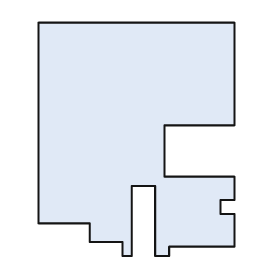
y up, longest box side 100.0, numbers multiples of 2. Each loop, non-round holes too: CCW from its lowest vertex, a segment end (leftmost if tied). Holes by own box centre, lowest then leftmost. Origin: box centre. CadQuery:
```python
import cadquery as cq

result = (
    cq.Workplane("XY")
    .moveTo(-6.0, -50.0)
    .lineTo(-2.0, -50.0)
    .lineTo(-2.0, -20.0)
    .lineTo(8.0, -20.0)
    .lineTo(8.0, -50.0)
    .lineTo(14.0, -50.0)
    .lineTo(14.0, -46.0)
    .lineTo(42.0, -46.0)
    .lineTo(42.0, -32.0)
    .lineTo(36.0, -32.0)
    .lineTo(36.0, -26.0)
    .lineTo(42.0, -26.0)
    .lineTo(42.0, -16.0)
    .lineTo(12.0, -16.0)
    .lineTo(12.0, 6.0)
    .lineTo(42.0, 6.0)
    .lineTo(42.0, 50.0)
    .lineTo(-42.0, 50.0)
    .lineTo(-42.0, -36.0)
    .lineTo(-20.0, -36.0)
    .lineTo(-20.0, -44.0)
    .lineTo(-6.0, -44.0)
    .close()
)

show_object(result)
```